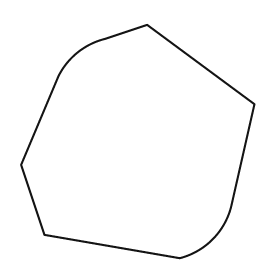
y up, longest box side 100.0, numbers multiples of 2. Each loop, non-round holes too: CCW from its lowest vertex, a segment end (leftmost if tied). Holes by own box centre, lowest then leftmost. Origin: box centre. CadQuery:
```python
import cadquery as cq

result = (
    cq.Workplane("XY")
    .moveTo(18.0, -50.0)
    .threePointArc((32.0, -42.0), (40.0, -28.0))
    .lineTo(50.0, 16.0)
    .lineTo(4.0, 50.0)
    .lineTo(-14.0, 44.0)
    .threePointArc((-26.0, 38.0), (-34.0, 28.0))
    .lineTo(-50.0, -10.0)
    .lineTo(-40.0, -40.0)
    .close()
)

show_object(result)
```